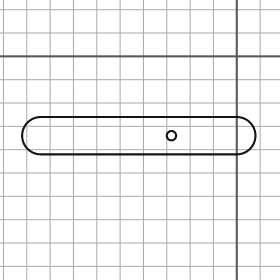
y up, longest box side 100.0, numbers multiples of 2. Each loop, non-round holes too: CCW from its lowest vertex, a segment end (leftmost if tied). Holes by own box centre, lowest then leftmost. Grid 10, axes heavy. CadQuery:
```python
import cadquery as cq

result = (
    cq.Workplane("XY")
    .moveTo(-84.0, -42.0)
    .lineTo(0.0, -42.0)
    .threePointArc((8.0, -34.0), (0.0, -26.0))
    .lineTo(-84.0, -26.0)
    .threePointArc((-92.0, -34.0), (-84.0, -42.0))
    .close()
    .moveTo(-28.0, -34.0)
    .circle(2.0)
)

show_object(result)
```